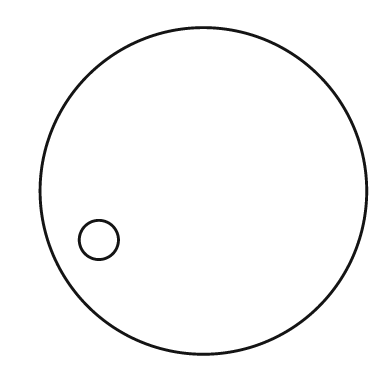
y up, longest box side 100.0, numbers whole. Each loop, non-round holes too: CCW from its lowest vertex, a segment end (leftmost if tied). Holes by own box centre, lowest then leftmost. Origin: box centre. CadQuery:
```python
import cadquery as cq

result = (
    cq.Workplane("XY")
    .moveTo(0.0, 0.0)
    .circle(50.0)
    .moveTo(-32.0, -15.0)
    .circle(6.0)
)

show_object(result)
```